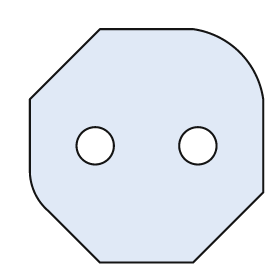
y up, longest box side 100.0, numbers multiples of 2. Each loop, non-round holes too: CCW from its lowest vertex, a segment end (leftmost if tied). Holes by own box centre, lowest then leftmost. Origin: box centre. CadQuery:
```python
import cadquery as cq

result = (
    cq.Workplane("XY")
    .moveTo(-20.0, -50.0)
    .lineTo(20.0, -50.0)
    .lineTo(50.0, -20.0)
    .lineTo(50.0, 20.0)
    .threePointArc((40.0, 40.0), (20.0, 50.0))
    .lineTo(-20.0, 50.0)
    .lineTo(-50.0, 20.0)
    .lineTo(-50.0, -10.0)
    .threePointArc((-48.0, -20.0), (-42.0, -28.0))
    .close()
    .moveTo(-22.0, 0.0)
    .circle(8.0)
    .moveTo(22.0, 0.0)
    .circle(8.0)
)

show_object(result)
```